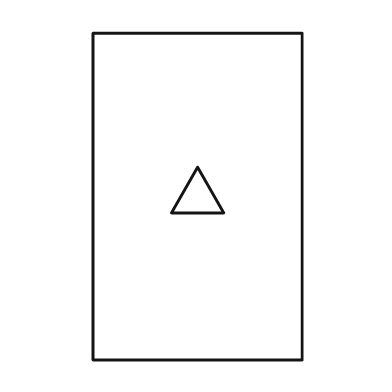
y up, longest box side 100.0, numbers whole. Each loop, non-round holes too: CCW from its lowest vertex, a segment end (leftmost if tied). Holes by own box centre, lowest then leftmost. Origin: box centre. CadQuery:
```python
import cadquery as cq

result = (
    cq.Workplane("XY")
    .moveTo(-32.0, -50.0)
    .lineTo(32.0, -50.0)
    .lineTo(32.0, 50.0)
    .lineTo(-32.0, 50.0)
    .close()
    .moveTo(-8.0, -5.0)
    .lineTo(8.0, -5.0)
    .lineTo(0.0, 9.0)
    .close()
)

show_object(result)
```